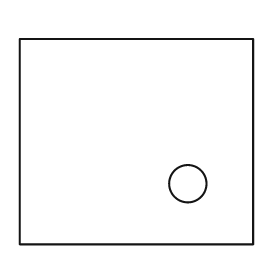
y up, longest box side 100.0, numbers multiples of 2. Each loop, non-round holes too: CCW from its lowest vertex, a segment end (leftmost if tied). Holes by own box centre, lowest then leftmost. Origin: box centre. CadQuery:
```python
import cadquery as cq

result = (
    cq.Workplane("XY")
    .moveTo(-50.0, -44.0)
    .lineTo(50.0, -44.0)
    .lineTo(50.0, 44.0)
    .lineTo(-50.0, 44.0)
    .close()
    .moveTo(22.0, -18.0)
    .circle(8.0)
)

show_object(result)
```